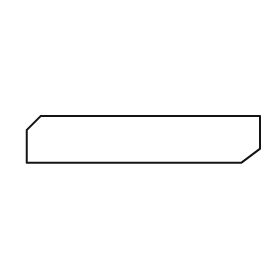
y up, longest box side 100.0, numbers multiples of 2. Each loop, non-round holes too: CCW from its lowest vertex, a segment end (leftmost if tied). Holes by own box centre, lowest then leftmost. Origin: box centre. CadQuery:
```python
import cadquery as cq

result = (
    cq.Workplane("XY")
    .moveTo(-50.0, -10.0)
    .lineTo(42.0, -10.0)
    .lineTo(50.0, -4.0)
    .lineTo(50.0, 10.0)
    .lineTo(-44.0, 10.0)
    .lineTo(-50.0, 4.0)
    .close()
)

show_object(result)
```